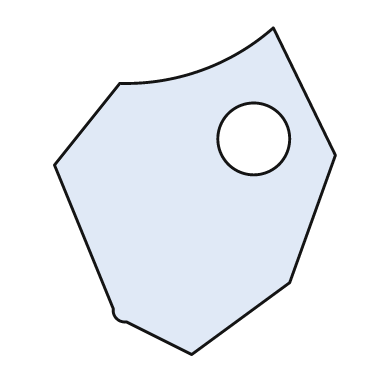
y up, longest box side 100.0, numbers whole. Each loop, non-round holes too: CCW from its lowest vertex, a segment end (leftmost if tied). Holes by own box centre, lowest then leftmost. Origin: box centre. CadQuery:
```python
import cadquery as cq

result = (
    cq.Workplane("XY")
    .moveTo(-1.0, -50.0)
    .lineTo(29.0, -28.0)
    .lineTo(43.0, 11.0)
    .lineTo(24.0, 50.0)
    .threePointArc((2.0, 37.0), (-23.0, 33.0))
    .lineTo(-43.0, 8.0)
    .lineTo(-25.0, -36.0)
    .threePointArc((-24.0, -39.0), (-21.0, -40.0))
    .close()
    .moveTo(18.0, 16.0)
    .circle(11.0)
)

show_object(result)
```